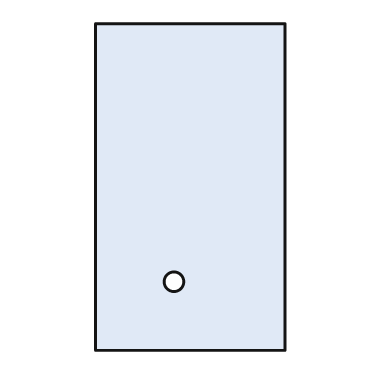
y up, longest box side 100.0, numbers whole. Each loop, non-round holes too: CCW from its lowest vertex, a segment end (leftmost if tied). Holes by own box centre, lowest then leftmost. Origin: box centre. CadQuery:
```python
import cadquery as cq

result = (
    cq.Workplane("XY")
    .moveTo(-29.0, -50.0)
    .lineTo(29.0, -50.0)
    .lineTo(29.0, 50.0)
    .lineTo(-29.0, 50.0)
    .close()
    .moveTo(-5.0, -29.0)
    .circle(3.0)
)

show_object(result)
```